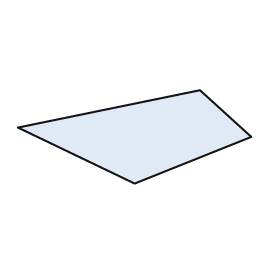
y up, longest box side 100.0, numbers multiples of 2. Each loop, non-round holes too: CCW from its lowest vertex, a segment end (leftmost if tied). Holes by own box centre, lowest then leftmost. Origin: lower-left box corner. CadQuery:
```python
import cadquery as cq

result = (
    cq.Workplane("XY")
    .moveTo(50.0, 0.0)
    .lineTo(100.0, 20.0)
    .lineTo(78.0, 40.0)
    .lineTo(0.0, 24.0)
    .close()
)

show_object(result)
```